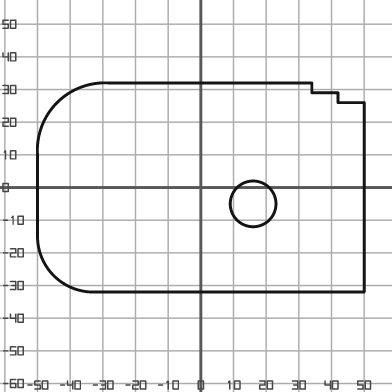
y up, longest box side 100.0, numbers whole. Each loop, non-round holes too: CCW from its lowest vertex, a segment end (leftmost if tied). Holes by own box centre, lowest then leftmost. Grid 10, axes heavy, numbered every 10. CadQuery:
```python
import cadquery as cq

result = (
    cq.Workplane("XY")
    .moveTo(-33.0, -32.0)
    .lineTo(50.0, -32.0)
    .lineTo(50.0, 26.0)
    .lineTo(42.0, 26.0)
    .lineTo(42.0, 29.0)
    .lineTo(34.0, 29.0)
    .lineTo(34.0, 32.0)
    .lineTo(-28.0, 32.0)
    .threePointArc((-44.0, 26.0), (-50.0, 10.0))
    .lineTo(-50.0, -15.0)
    .threePointArc((-45.0, -27.0), (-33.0, -32.0))
    .close()
    .moveTo(16.0, -5.0)
    .circle(7.0)
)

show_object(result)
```